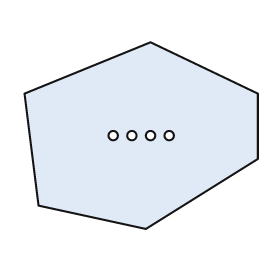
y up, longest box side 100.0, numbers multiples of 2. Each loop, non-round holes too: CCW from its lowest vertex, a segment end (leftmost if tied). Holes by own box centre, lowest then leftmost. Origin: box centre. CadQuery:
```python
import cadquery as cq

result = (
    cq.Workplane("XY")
    .moveTo(2.0, -40.0)
    .lineTo(50.0, -10.0)
    .lineTo(50.0, 18.0)
    .lineTo(4.0, 40.0)
    .lineTo(-50.0, 18.0)
    .lineTo(-44.0, -30.0)
    .close()
    .moveTo(-12.0, 0.0)
    .circle(2.0)
    .moveTo(-4.0, 0.0)
    .circle(2.0)
    .moveTo(4.0, 0.0)
    .circle(2.0)
    .moveTo(12.0, 0.0)
    .circle(2.0)
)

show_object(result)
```